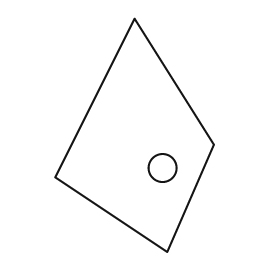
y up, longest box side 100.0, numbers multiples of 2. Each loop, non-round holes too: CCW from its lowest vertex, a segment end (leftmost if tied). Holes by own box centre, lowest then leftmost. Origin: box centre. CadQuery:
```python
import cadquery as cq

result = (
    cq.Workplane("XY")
    .moveTo(14.0, -50.0)
    .lineTo(34.0, -4.0)
    .lineTo(0.0, 50.0)
    .lineTo(-34.0, -18.0)
    .close()
    .moveTo(12.0, -14.0)
    .circle(6.0)
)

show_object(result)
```